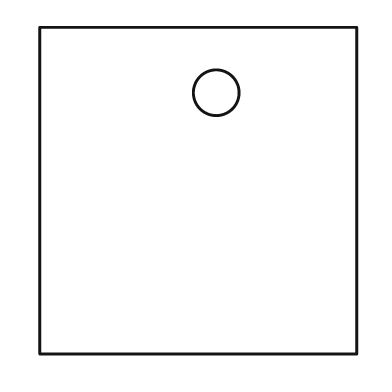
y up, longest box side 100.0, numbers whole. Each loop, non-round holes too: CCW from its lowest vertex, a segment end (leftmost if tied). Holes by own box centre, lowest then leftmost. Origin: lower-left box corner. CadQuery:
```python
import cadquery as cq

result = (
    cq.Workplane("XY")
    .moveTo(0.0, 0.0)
    .lineTo(97.0, 0.0)
    .lineTo(97.0, 100.0)
    .lineTo(0.0, 100.0)
    .close()
    .moveTo(54.0, 80.0)
    .circle(7.0)
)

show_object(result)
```